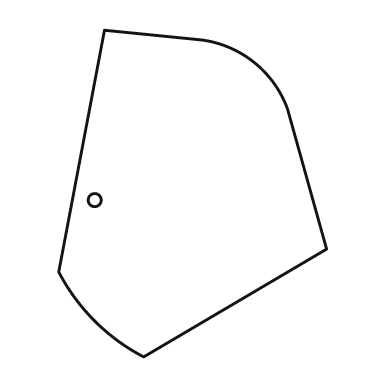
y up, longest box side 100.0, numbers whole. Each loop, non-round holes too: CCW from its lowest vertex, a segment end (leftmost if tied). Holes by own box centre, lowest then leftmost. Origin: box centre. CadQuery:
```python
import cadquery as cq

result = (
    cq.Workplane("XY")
    .moveTo(-15.0, -50.0)
    .lineTo(41.0, -17.0)
    .lineTo(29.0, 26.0)
    .threePointArc((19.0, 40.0), (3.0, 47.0))
    .lineTo(-27.0, 50.0)
    .lineTo(-41.0, -24.0)
    .threePointArc((-30.0, -39.0), (-15.0, -50.0))
    .close()
    .moveTo(-30.0, -2.0)
    .circle(2.0)
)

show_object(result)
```